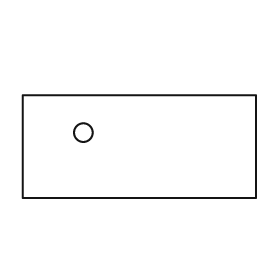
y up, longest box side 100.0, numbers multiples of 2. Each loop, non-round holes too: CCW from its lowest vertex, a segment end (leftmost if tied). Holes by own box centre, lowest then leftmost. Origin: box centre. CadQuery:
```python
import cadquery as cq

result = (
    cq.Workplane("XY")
    .moveTo(-50.0, -22.0)
    .lineTo(50.0, -22.0)
    .lineTo(50.0, 22.0)
    .lineTo(-50.0, 22.0)
    .close()
    .moveTo(-24.0, 6.0)
    .circle(4.0)
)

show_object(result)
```